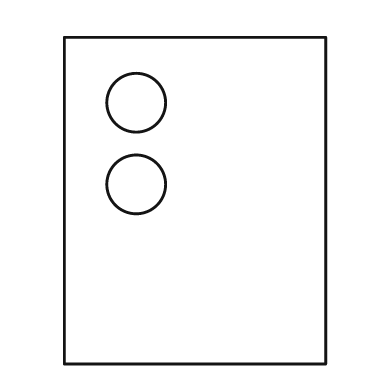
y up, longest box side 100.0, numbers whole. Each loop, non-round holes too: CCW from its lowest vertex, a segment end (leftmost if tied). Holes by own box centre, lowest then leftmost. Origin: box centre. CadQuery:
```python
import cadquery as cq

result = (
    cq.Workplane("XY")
    .moveTo(-40.0, -50.0)
    .lineTo(40.0, -50.0)
    .lineTo(40.0, 50.0)
    .lineTo(-40.0, 50.0)
    .close()
    .moveTo(-18.0, 5.0)
    .circle(9.0)
    .moveTo(-18.0, 30.0)
    .circle(9.0)
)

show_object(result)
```